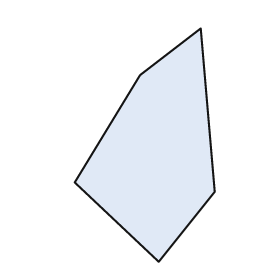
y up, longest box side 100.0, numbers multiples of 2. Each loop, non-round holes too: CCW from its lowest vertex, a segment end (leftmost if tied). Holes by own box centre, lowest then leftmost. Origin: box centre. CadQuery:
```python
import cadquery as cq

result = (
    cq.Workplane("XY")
    .moveTo(6.0, -50.0)
    .lineTo(30.0, -20.0)
    .lineTo(24.0, 50.0)
    .lineTo(-2.0, 30.0)
    .lineTo(-30.0, -16.0)
    .close()
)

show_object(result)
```